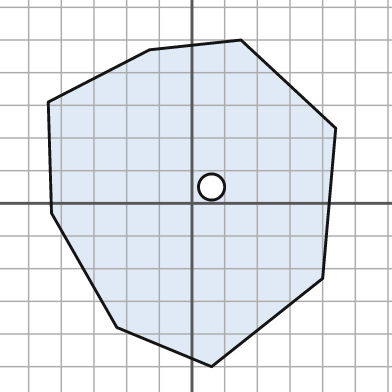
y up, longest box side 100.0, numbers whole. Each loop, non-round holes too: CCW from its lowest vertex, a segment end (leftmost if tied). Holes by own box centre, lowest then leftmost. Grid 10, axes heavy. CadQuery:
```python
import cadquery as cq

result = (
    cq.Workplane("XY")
    .moveTo(6.0, -50.0)
    .lineTo(40.0, -23.0)
    .lineTo(44.0, 23.0)
    .lineTo(15.0, 50.0)
    .lineTo(-13.0, 47.0)
    .lineTo(-44.0, 31.0)
    .lineTo(-43.0, -3.0)
    .lineTo(-23.0, -38.0)
    .close()
    .moveTo(6.0, 5.0)
    .circle(4.0)
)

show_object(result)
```